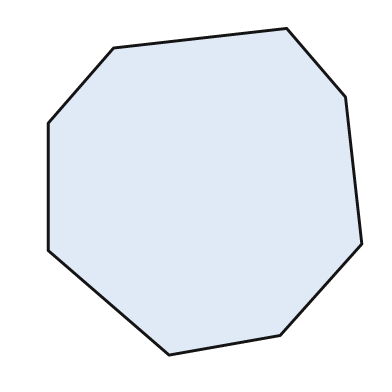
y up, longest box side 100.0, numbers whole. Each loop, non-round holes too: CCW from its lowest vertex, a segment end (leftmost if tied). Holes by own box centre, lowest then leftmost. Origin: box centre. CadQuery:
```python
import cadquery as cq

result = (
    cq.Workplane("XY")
    .moveTo(-11.0, -50.0)
    .lineTo(23.0, -44.0)
    .lineTo(48.0, -16.0)
    .lineTo(43.0, 29.0)
    .lineTo(25.0, 50.0)
    .lineTo(-28.0, 44.0)
    .lineTo(-48.0, 21.0)
    .lineTo(-48.0, -18.0)
    .close()
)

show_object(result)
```